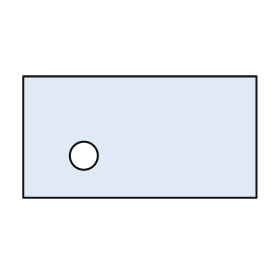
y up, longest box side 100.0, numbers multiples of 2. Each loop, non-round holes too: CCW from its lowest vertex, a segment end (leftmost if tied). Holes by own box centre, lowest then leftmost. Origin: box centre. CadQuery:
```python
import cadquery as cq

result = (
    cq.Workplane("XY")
    .moveTo(-50.0, -26.0)
    .lineTo(50.0, -26.0)
    .lineTo(50.0, 26.0)
    .lineTo(-50.0, 26.0)
    .close()
    .moveTo(-24.0, -8.0)
    .circle(6.0)
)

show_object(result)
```